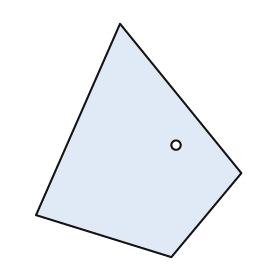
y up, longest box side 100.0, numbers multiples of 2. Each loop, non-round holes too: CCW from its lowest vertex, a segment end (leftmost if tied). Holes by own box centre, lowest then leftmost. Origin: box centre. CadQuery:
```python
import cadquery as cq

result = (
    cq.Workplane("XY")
    .moveTo(14.0, -50.0)
    .lineTo(44.0, -14.0)
    .lineTo(-8.0, 50.0)
    .lineTo(-44.0, -32.0)
    .close()
    .moveTo(16.0, -2.0)
    .circle(2.0)
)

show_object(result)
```